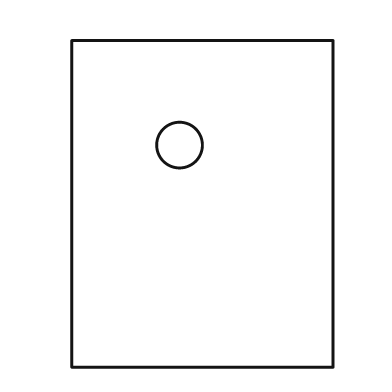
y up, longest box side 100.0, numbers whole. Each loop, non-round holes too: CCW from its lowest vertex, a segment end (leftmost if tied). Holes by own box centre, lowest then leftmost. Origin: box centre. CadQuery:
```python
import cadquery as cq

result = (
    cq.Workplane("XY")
    .moveTo(-40.0, -50.0)
    .lineTo(40.0, -50.0)
    .lineTo(40.0, 50.0)
    .lineTo(-40.0, 50.0)
    .close()
    .moveTo(-7.0, 18.0)
    .circle(7.0)
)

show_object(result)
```